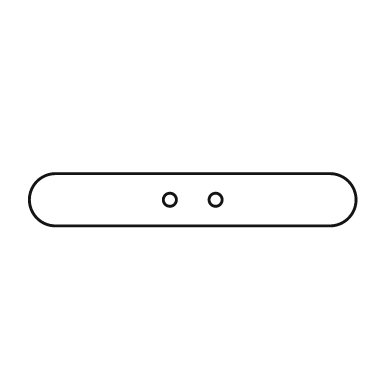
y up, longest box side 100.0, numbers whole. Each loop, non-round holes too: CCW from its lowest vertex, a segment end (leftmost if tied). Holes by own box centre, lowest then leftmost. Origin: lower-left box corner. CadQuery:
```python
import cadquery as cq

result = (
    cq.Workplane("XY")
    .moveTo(8.0, 0.0)
    .lineTo(92.0, 0.0)
    .threePointArc((100.0, 8.0), (92.0, 16.0))
    .lineTo(8.0, 16.0)
    .threePointArc((0.0, 8.0), (8.0, 0.0))
    .close()
    .moveTo(43.0, 8.0)
    .circle(2.0)
    .moveTo(57.0, 8.0)
    .circle(2.0)
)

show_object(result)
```